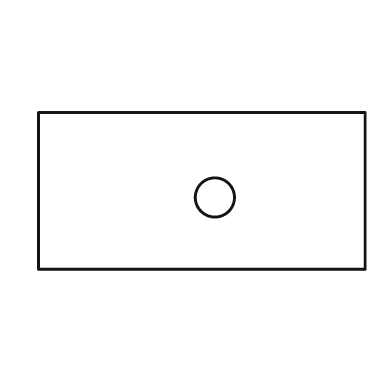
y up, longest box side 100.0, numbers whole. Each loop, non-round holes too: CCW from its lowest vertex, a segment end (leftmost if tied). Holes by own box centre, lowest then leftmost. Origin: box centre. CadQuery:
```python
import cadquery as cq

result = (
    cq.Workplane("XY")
    .moveTo(-50.0, -24.0)
    .lineTo(50.0, -24.0)
    .lineTo(50.0, 24.0)
    .lineTo(-50.0, 24.0)
    .close()
    .moveTo(4.0, -2.0)
    .circle(6.0)
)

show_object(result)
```